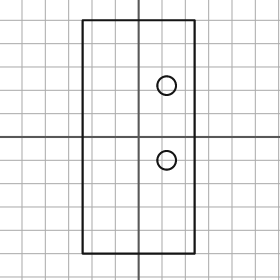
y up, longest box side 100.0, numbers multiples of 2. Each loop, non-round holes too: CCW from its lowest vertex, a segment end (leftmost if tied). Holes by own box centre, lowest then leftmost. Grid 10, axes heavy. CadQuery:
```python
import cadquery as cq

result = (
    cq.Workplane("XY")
    .moveTo(-24.0, -50.0)
    .lineTo(24.0, -50.0)
    .lineTo(24.0, 50.0)
    .lineTo(-24.0, 50.0)
    .close()
    .moveTo(12.0, -10.0)
    .circle(4.0)
    .moveTo(12.0, 22.0)
    .circle(4.0)
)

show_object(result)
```